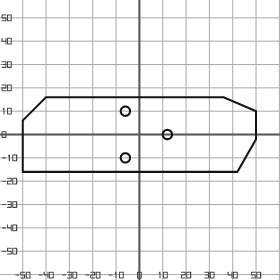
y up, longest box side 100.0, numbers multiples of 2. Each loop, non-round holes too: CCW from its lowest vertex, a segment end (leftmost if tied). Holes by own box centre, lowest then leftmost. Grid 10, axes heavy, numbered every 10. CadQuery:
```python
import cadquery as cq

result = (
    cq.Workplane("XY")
    .moveTo(-50.0, -16.0)
    .lineTo(42.0, -16.0)
    .lineTo(50.0, -2.0)
    .lineTo(50.0, 10.0)
    .lineTo(36.0, 16.0)
    .lineTo(-40.0, 16.0)
    .lineTo(-50.0, 6.0)
    .close()
    .moveTo(-6.0, -10.0)
    .circle(2.0)
    .moveTo(12.0, 0.0)
    .circle(2.0)
    .moveTo(-6.0, 10.0)
    .circle(2.0)
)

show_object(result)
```